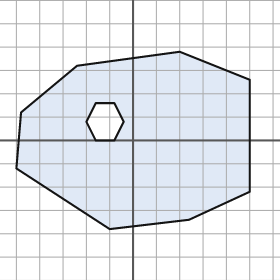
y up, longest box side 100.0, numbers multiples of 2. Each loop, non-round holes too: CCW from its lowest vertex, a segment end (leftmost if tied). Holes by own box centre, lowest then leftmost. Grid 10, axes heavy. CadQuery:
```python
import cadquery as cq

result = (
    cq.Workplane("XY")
    .moveTo(-10.0, -38.0)
    .lineTo(24.0, -34.0)
    .lineTo(50.0, -22.0)
    .lineTo(50.0, 26.0)
    .lineTo(20.0, 38.0)
    .lineTo(-24.0, 32.0)
    .lineTo(-48.0, 12.0)
    .lineTo(-50.0, -12.0)
    .close()
    .moveTo(-16.0, 0.0)
    .lineTo(-8.0, 0.0)
    .lineTo(-4.0, 8.0)
    .lineTo(-8.0, 16.0)
    .lineTo(-16.0, 16.0)
    .lineTo(-20.0, 8.0)
    .close()
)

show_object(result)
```